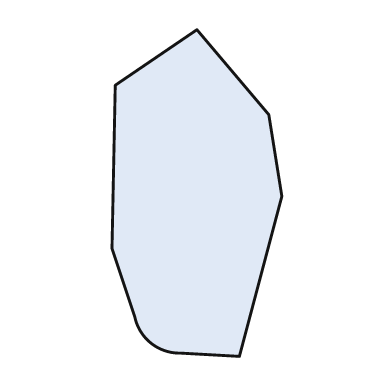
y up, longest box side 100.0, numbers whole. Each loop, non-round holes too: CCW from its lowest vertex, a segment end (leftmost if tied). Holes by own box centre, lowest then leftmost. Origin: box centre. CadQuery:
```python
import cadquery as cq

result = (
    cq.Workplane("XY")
    .moveTo(13.0, -50.0)
    .lineTo(26.0, -1.0)
    .lineTo(22.0, 24.0)
    .lineTo(0.0, 50.0)
    .lineTo(-25.0, 33.0)
    .lineTo(-26.0, -17.0)
    .lineTo(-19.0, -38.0)
    .threePointArc((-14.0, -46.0), (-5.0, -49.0))
    .close()
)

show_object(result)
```